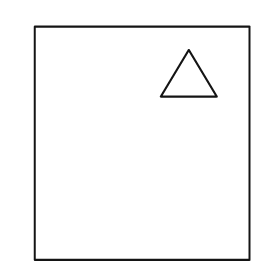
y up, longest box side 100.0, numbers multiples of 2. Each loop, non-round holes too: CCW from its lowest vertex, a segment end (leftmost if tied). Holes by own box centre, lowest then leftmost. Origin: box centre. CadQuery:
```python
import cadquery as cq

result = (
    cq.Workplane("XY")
    .moveTo(-46.0, -50.0)
    .lineTo(46.0, -50.0)
    .lineTo(46.0, 50.0)
    .lineTo(-46.0, 50.0)
    .close()
    .moveTo(8.0, 20.0)
    .lineTo(32.0, 20.0)
    .lineTo(20.0, 40.0)
    .close()
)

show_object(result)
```